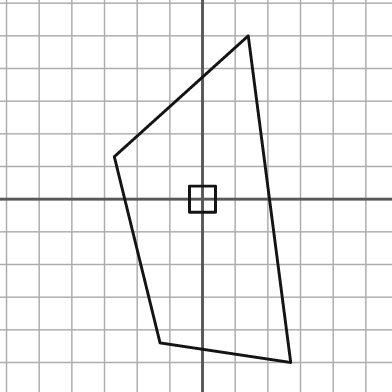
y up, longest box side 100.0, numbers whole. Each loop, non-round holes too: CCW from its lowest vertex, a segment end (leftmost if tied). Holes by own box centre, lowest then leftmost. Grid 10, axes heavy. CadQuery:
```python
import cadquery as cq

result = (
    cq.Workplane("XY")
    .moveTo(27.0, -50.0)
    .lineTo(14.0, 50.0)
    .lineTo(-27.0, 13.0)
    .lineTo(-13.0, -44.0)
    .close()
    .moveTo(-4.0, -4.0)
    .lineTo(4.0, -4.0)
    .lineTo(4.0, 4.0)
    .lineTo(-4.0, 4.0)
    .close()
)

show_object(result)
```